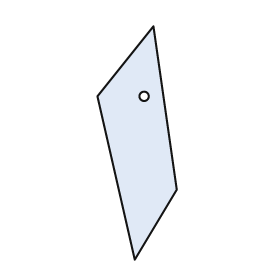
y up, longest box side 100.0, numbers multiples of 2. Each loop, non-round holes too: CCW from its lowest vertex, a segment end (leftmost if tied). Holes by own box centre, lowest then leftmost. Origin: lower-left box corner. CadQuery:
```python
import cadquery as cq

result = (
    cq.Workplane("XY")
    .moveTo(16.0, 0.0)
    .lineTo(34.0, 30.0)
    .lineTo(24.0, 100.0)
    .lineTo(0.0, 70.0)
    .close()
    .moveTo(20.0, 70.0)
    .circle(2.0)
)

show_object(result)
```